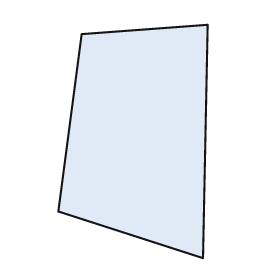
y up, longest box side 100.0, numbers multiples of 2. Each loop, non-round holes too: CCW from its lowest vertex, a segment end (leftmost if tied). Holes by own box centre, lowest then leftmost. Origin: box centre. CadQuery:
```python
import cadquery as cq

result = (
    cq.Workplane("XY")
    .moveTo(30.0, -50.0)
    .lineTo(32.0, 50.0)
    .lineTo(-22.0, 46.0)
    .lineTo(-32.0, -30.0)
    .close()
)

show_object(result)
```